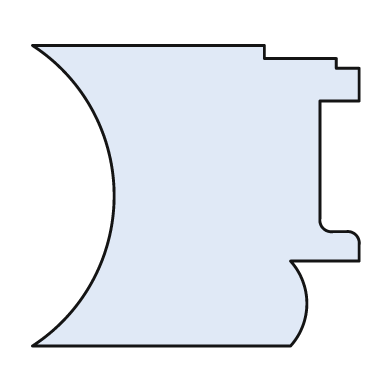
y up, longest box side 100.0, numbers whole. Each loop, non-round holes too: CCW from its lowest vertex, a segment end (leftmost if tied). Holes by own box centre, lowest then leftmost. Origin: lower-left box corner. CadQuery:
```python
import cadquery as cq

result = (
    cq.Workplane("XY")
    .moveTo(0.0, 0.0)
    .lineTo(79.0, 0.0)
    .threePointArc((84.0, 13.0), (79.0, 26.0))
    .lineTo(100.0, 26.0)
    .lineTo(100.0, 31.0)
    .threePointArc((99.0, 34.0), (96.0, 35.0))
    .lineTo(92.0, 35.0)
    .threePointArc((89.0, 36.0), (88.0, 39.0))
    .lineTo(88.0, 75.0)
    .lineTo(100.0, 75.0)
    .lineTo(100.0, 85.0)
    .lineTo(93.0, 85.0)
    .lineTo(93.0, 88.0)
    .lineTo(71.0, 88.0)
    .lineTo(71.0, 92.0)
    .lineTo(0.0, 92.0)
    .threePointArc((25.0, 46.0), (0.0, 0.0))
    .close()
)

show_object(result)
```